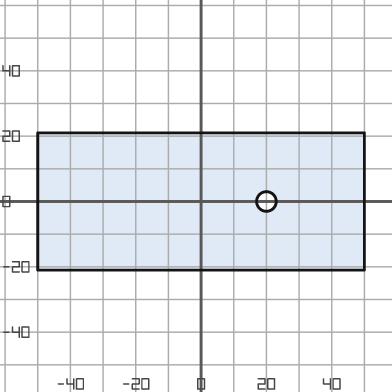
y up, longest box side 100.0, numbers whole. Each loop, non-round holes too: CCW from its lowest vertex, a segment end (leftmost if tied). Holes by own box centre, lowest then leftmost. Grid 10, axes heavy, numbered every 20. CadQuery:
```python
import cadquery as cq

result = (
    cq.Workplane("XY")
    .moveTo(-50.0, -21.0)
    .lineTo(50.0, -21.0)
    .lineTo(50.0, 21.0)
    .lineTo(-50.0, 21.0)
    .close()
    .moveTo(20.0, 0.0)
    .circle(3.0)
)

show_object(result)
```